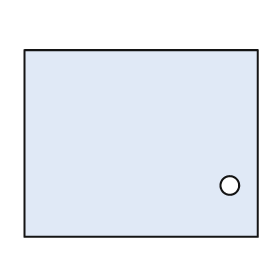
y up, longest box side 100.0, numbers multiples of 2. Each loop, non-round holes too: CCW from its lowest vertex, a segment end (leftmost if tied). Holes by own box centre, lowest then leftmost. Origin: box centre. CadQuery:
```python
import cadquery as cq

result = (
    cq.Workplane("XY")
    .moveTo(-50.0, -40.0)
    .lineTo(50.0, -40.0)
    .lineTo(50.0, 40.0)
    .lineTo(-50.0, 40.0)
    .close()
    .moveTo(38.0, -18.0)
    .circle(4.0)
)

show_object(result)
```